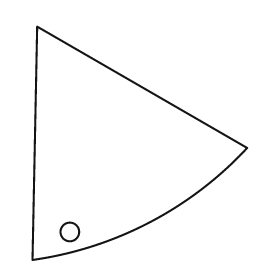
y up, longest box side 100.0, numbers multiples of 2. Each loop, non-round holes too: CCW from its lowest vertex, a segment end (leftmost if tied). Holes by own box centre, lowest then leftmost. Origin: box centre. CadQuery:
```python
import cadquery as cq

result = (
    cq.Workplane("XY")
    .moveTo(-46.0, -50.0)
    .threePointArc((4.0, -34.0), (46.0, -2.0))
    .lineTo(-44.0, 50.0)
    .close()
    .moveTo(-30.0, -38.0)
    .circle(4.0)
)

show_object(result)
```